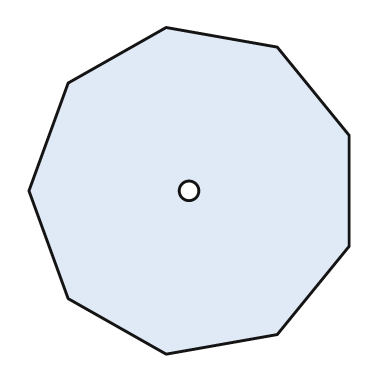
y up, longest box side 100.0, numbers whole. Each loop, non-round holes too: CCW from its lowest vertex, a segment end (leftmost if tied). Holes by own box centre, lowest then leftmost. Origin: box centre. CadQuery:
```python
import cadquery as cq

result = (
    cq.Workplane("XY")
    .moveTo(-7.0, -50.0)
    .lineTo(27.0, -44.0)
    .lineTo(49.0, -17.0)
    .lineTo(49.0, 17.0)
    .lineTo(27.0, 44.0)
    .lineTo(-7.0, 50.0)
    .lineTo(-37.0, 33.0)
    .lineTo(-49.0, 0.0)
    .lineTo(-37.0, -33.0)
    .close()
    .moveTo(0.0, 0.0)
    .circle(3.0)
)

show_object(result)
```